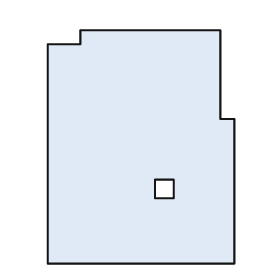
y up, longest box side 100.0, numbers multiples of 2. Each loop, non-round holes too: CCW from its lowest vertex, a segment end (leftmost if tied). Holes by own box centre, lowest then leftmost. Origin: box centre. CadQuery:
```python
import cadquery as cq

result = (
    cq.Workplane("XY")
    .moveTo(-40.0, -50.0)
    .lineTo(40.0, -50.0)
    .lineTo(40.0, 12.0)
    .lineTo(34.0, 12.0)
    .lineTo(34.0, 50.0)
    .lineTo(-26.0, 50.0)
    .lineTo(-26.0, 44.0)
    .lineTo(-40.0, 44.0)
    .close()
    .moveTo(6.0, -22.0)
    .lineTo(14.0, -22.0)
    .lineTo(14.0, -14.0)
    .lineTo(6.0, -14.0)
    .close()
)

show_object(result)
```